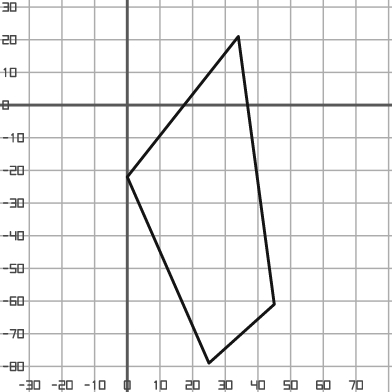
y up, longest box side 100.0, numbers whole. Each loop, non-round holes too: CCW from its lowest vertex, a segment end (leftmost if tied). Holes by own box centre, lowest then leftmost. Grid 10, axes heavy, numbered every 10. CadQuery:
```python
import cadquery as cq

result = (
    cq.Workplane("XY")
    .moveTo(25.0, -79.0)
    .lineTo(45.0, -61.0)
    .lineTo(34.0, 21.0)
    .lineTo(0.0, -22.0)
    .close()
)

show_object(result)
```